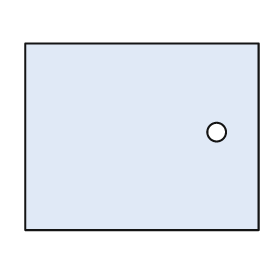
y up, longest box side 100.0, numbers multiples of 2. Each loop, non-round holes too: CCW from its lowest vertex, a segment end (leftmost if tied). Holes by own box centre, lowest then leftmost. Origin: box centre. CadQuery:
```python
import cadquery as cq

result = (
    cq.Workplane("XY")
    .moveTo(-50.0, -40.0)
    .lineTo(50.0, -40.0)
    .lineTo(50.0, 40.0)
    .lineTo(-50.0, 40.0)
    .close()
    .moveTo(32.0, 2.0)
    .circle(4.0)
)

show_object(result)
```